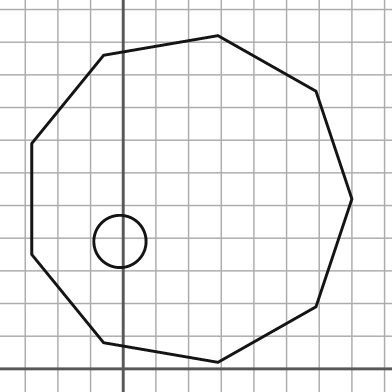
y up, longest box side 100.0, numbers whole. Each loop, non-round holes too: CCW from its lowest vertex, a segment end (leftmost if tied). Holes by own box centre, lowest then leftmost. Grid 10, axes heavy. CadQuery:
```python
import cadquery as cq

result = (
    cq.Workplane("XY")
    .moveTo(29.0, 2.0)
    .lineTo(59.0, 19.0)
    .lineTo(70.0, 52.0)
    .lineTo(59.0, 85.0)
    .lineTo(29.0, 102.0)
    .lineTo(-6.0, 96.0)
    .lineTo(-28.0, 69.0)
    .lineTo(-28.0, 35.0)
    .lineTo(-6.0, 8.0)
    .close()
    .moveTo(-1.0, 39.0)
    .circle(8.0)
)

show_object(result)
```